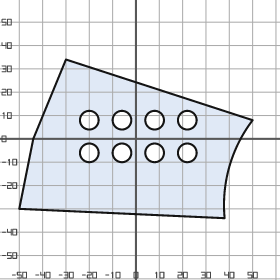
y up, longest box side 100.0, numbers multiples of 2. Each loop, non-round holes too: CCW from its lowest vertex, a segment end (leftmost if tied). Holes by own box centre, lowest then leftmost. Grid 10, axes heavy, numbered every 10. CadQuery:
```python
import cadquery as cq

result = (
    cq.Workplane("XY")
    .moveTo(38.0, -34.0)
    .threePointArc((40.0, -12.0), (50.0, 8.0))
    .lineTo(-30.0, 34.0)
    .lineTo(-44.0, 0.0)
    .lineTo(-50.0, -30.0)
    .close()
    .moveTo(-20.0, -6.0)
    .circle(4.0)
    .moveTo(-6.0, -6.0)
    .circle(4.0)
    .moveTo(8.0, -6.0)
    .circle(4.0)
    .moveTo(22.0, -6.0)
    .circle(4.0)
    .moveTo(-20.0, 8.0)
    .circle(4.0)
    .moveTo(-6.0, 8.0)
    .circle(4.0)
    .moveTo(8.0, 8.0)
    .circle(4.0)
    .moveTo(22.0, 8.0)
    .circle(4.0)
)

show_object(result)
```